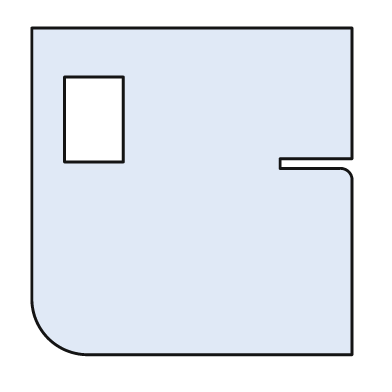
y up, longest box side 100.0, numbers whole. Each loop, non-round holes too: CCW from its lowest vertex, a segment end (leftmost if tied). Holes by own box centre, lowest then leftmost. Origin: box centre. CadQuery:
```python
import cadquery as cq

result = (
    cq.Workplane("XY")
    .moveTo(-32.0, -50.0)
    .lineTo(49.0, -50.0)
    .lineTo(49.0, 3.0)
    .threePointArc((48.0, 6.0), (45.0, 7.0))
    .lineTo(27.0, 7.0)
    .lineTo(27.0, 10.0)
    .lineTo(49.0, 10.0)
    .lineTo(49.0, 50.0)
    .lineTo(-49.0, 50.0)
    .lineTo(-49.0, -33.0)
    .threePointArc((-44.0, -45.0), (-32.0, -50.0))
    .close()
    .moveTo(-39.0, 9.0)
    .lineTo(-21.0, 9.0)
    .lineTo(-21.0, 35.0)
    .lineTo(-39.0, 35.0)
    .close()
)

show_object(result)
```